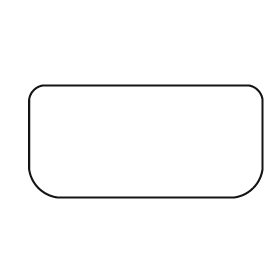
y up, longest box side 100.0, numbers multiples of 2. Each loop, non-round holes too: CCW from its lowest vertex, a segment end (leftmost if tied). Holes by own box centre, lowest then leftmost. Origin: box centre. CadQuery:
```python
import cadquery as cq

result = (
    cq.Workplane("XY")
    .moveTo(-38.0, -24.0)
    .lineTo(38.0, -24.0)
    .threePointArc((46.0, -20.0), (50.0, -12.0))
    .lineTo(50.0, 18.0)
    .threePointArc((48.0, 22.0), (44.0, 24.0))
    .lineTo(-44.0, 24.0)
    .threePointArc((-48.0, 22.0), (-50.0, 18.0))
    .lineTo(-50.0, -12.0)
    .threePointArc((-46.0, -20.0), (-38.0, -24.0))
    .close()
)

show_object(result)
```